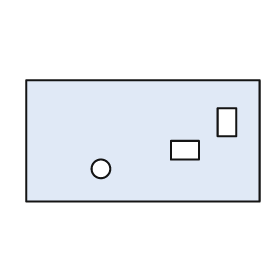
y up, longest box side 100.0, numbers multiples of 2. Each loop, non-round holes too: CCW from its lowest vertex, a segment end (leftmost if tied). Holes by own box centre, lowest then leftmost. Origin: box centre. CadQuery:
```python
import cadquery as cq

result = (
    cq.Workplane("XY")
    .moveTo(-50.0, -26.0)
    .lineTo(50.0, -26.0)
    .lineTo(50.0, 26.0)
    .lineTo(-50.0, 26.0)
    .close()
    .moveTo(-18.0, -12.0)
    .circle(4.0)
    .moveTo(12.0, -8.0)
    .lineTo(24.0, -8.0)
    .lineTo(24.0, 0.0)
    .lineTo(12.0, 0.0)
    .close()
    .moveTo(32.0, 2.0)
    .lineTo(40.0, 2.0)
    .lineTo(40.0, 14.0)
    .lineTo(32.0, 14.0)
    .close()
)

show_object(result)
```